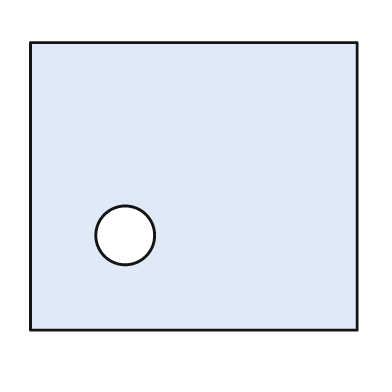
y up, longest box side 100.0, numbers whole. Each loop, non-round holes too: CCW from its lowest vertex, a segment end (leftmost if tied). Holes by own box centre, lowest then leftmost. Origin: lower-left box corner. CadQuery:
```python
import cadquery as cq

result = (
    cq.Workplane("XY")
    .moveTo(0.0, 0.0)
    .lineTo(100.0, 0.0)
    .lineTo(100.0, 88.0)
    .lineTo(0.0, 88.0)
    .close()
    .moveTo(29.0, 29.0)
    .circle(9.0)
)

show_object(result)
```